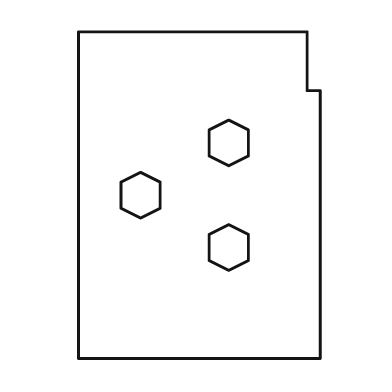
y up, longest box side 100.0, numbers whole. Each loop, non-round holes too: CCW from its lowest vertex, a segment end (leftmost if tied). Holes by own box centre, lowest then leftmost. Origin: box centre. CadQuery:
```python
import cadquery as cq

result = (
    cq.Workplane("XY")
    .moveTo(-37.0, -50.0)
    .lineTo(37.0, -50.0)
    .lineTo(37.0, 32.0)
    .lineTo(33.0, 32.0)
    .lineTo(33.0, 50.0)
    .lineTo(-37.0, 50.0)
    .close()
    .moveTo(9.0, -23.0)
    .lineTo(15.0, -20.0)
    .lineTo(15.0, -12.0)
    .lineTo(9.0, -9.0)
    .lineTo(3.0, -12.0)
    .lineTo(3.0, -20.0)
    .close()
    .moveTo(-18.0, -7.0)
    .lineTo(-12.0, -4.0)
    .lineTo(-12.0, 4.0)
    .lineTo(-18.0, 7.0)
    .lineTo(-24.0, 4.0)
    .lineTo(-24.0, -4.0)
    .close()
    .moveTo(9.0, 9.0)
    .lineTo(15.0, 12.0)
    .lineTo(15.0, 20.0)
    .lineTo(9.0, 23.0)
    .lineTo(3.0, 20.0)
    .lineTo(3.0, 12.0)
    .close()
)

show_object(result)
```